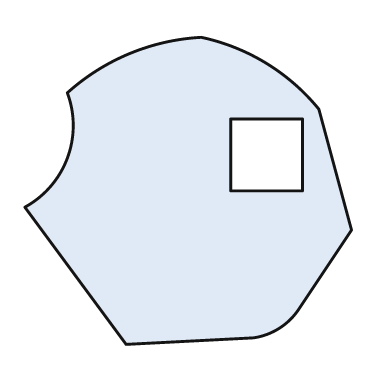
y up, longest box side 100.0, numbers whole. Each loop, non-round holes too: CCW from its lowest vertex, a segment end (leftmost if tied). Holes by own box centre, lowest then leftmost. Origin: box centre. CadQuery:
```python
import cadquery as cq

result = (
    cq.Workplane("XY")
    .moveTo(-19.0, -47.0)
    .lineTo(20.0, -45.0)
    .threePointArc((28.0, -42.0), (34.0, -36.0))
    .lineTo(50.0, -12.0)
    .lineTo(40.0, 25.0)
    .threePointArc((24.0, 39.0), (4.0, 47.0))
    .threePointArc((-18.0, 42.0), (-37.0, 30.0))
    .threePointArc((-37.0, 10.0), (-50.0, -5.0))
    .close()
    .moveTo(13.0, 0.0)
    .lineTo(35.0, 0.0)
    .lineTo(35.0, 22.0)
    .lineTo(13.0, 22.0)
    .close()
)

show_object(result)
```